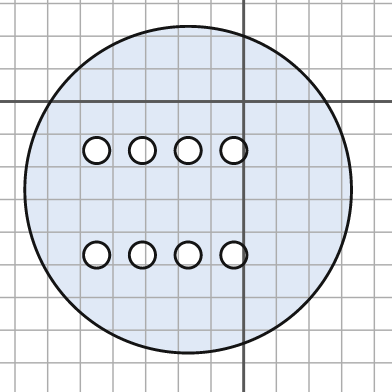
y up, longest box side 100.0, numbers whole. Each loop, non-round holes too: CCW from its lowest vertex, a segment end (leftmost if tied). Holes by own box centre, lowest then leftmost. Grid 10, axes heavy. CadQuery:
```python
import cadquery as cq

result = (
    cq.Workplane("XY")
    .moveTo(-17.0, -27.0)
    .circle(50.0)
    .moveTo(-45.0, -47.0)
    .circle(4.0)
    .moveTo(-31.0, -47.0)
    .circle(4.0)
    .moveTo(-17.0, -47.0)
    .circle(4.0)
    .moveTo(-3.0, -47.0)
    .circle(4.0)
    .moveTo(-45.0, -15.0)
    .circle(4.0)
    .moveTo(-31.0, -15.0)
    .circle(4.0)
    .moveTo(-17.0, -15.0)
    .circle(4.0)
    .moveTo(-3.0, -15.0)
    .circle(4.0)
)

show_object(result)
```